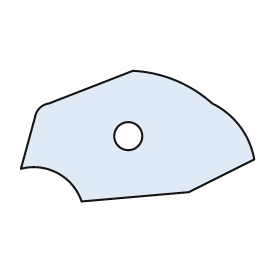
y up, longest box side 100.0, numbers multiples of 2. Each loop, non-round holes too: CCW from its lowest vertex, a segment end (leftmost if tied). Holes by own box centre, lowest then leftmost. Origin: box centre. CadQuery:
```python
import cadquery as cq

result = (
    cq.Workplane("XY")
    .moveTo(-24.0, -28.0)
    .lineTo(22.0, -24.0)
    .lineTo(50.0, -10.0)
    .threePointArc((44.0, 4.0), (32.0, 14.0))
    .threePointArc((16.0, 24.0), (-2.0, 28.0))
    .lineTo(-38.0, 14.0)
    .threePointArc((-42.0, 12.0), (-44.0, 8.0))
    .lineTo(-50.0, -14.0)
    .threePointArc((-34.0, -16.0), (-24.0, -28.0))
    .close()
    .moveTo(-4.0, 0.0)
    .circle(6.0)
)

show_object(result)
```